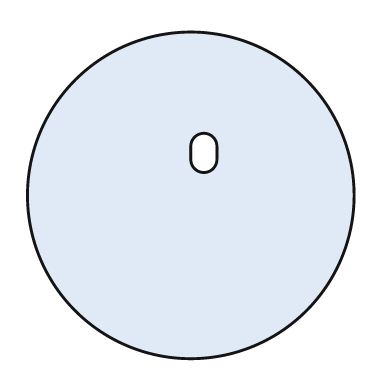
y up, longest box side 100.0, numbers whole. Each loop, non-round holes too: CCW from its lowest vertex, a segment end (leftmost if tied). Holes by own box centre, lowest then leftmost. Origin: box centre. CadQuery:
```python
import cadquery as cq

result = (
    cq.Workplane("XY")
    .moveTo(0.0, 0.0)
    .circle(50.0)
    .moveTo(0.0, 11.0)
    .threePointArc((4.0, 7.0), (8.0, 11.0))
    .lineTo(8.0, 15.0)
    .threePointArc((4.0, 19.0), (0.0, 15.0))
    .close()
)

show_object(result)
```